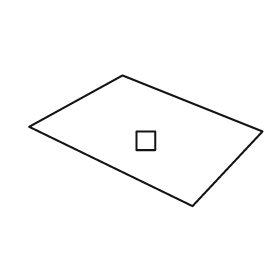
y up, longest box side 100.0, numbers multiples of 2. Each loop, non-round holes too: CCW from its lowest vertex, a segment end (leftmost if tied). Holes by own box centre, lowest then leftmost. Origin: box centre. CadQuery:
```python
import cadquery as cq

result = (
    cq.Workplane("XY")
    .moveTo(20.0, -28.0)
    .lineTo(50.0, 4.0)
    .lineTo(-10.0, 28.0)
    .lineTo(-50.0, 6.0)
    .close()
    .moveTo(-4.0, -4.0)
    .lineTo(4.0, -4.0)
    .lineTo(4.0, 4.0)
    .lineTo(-4.0, 4.0)
    .close()
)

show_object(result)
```